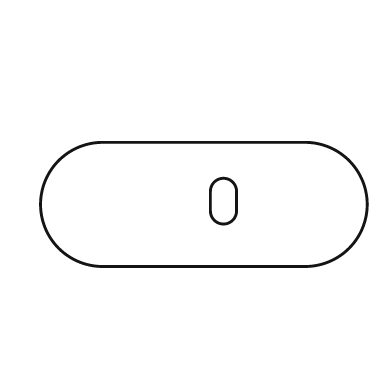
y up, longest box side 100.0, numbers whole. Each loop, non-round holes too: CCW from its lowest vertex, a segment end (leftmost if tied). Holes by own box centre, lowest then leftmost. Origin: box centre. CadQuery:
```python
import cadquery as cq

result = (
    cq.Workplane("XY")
    .moveTo(-31.0, -19.0)
    .lineTo(31.0, -19.0)
    .threePointArc((50.0, 0.0), (31.0, 19.0))
    .lineTo(-31.0, 19.0)
    .threePointArc((-50.0, 0.0), (-31.0, -19.0))
    .close()
    .moveTo(2.0, -2.0)
    .threePointArc((6.0, -6.0), (10.0, -2.0))
    .lineTo(10.0, 4.0)
    .threePointArc((6.0, 8.0), (2.0, 4.0))
    .close()
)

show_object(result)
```